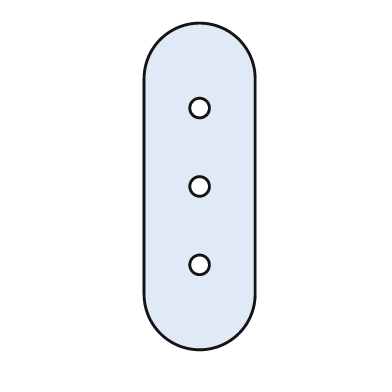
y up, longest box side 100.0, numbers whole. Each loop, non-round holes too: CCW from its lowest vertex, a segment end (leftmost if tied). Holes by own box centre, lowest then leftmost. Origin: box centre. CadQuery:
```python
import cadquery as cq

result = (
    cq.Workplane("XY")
    .moveTo(-17.0, -33.0)
    .threePointArc((0.0, -50.0), (17.0, -33.0))
    .lineTo(17.0, 33.0)
    .threePointArc((0.0, 50.0), (-17.0, 33.0))
    .close()
    .moveTo(0.0, -24.0)
    .circle(3.0)
    .moveTo(0.0, 0.0)
    .circle(3.0)
    .moveTo(0.0, 24.0)
    .circle(3.0)
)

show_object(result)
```